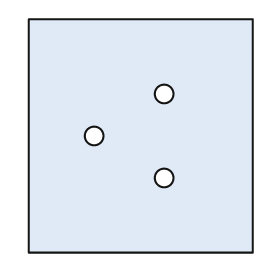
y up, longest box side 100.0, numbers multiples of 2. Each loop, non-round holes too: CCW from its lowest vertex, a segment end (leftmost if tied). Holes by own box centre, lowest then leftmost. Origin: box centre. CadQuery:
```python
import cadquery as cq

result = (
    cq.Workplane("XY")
    .moveTo(-48.0, -50.0)
    .lineTo(48.0, -50.0)
    .lineTo(48.0, 50.0)
    .lineTo(-48.0, 50.0)
    .close()
    .moveTo(10.0, -18.0)
    .circle(4.0)
    .moveTo(-20.0, 0.0)
    .circle(4.0)
    .moveTo(10.0, 18.0)
    .circle(4.0)
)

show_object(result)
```